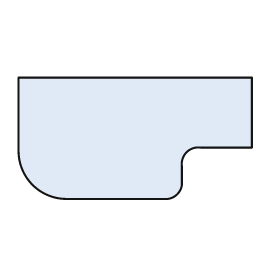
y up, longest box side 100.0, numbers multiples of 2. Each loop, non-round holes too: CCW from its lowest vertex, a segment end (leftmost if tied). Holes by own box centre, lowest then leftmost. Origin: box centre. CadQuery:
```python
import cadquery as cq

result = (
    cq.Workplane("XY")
    .moveTo(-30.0, -26.0)
    .lineTo(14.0, -26.0)
    .threePointArc((18.0, -24.0), (20.0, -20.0))
    .lineTo(20.0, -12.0)
    .threePointArc((22.0, -6.0), (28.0, -4.0))
    .lineTo(50.0, -4.0)
    .lineTo(50.0, 26.0)
    .lineTo(-50.0, 26.0)
    .lineTo(-50.0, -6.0)
    .threePointArc((-44.0, -20.0), (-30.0, -26.0))
    .close()
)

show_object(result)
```